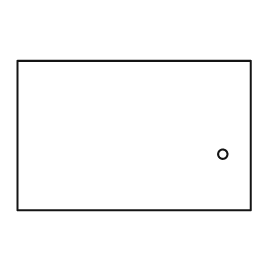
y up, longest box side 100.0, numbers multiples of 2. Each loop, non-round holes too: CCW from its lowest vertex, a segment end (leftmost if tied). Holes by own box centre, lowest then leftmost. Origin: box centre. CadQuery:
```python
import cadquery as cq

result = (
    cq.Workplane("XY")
    .moveTo(-50.0, -32.0)
    .lineTo(50.0, -32.0)
    .lineTo(50.0, 32.0)
    .lineTo(-50.0, 32.0)
    .close()
    .moveTo(38.0, -8.0)
    .circle(2.0)
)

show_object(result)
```